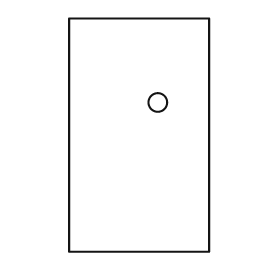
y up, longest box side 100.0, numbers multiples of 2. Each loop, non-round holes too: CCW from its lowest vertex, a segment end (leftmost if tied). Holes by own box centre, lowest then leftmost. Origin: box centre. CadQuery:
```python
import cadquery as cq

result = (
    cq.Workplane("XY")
    .moveTo(-30.0, -50.0)
    .lineTo(30.0, -50.0)
    .lineTo(30.0, 50.0)
    .lineTo(-30.0, 50.0)
    .close()
    .moveTo(8.0, 14.0)
    .circle(4.0)
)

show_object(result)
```